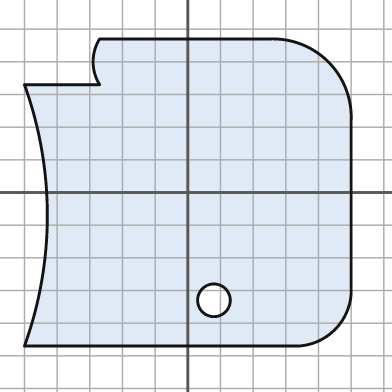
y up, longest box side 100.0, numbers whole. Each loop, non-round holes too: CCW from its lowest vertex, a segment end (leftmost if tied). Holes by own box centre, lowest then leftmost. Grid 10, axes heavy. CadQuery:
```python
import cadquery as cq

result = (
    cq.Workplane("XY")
    .moveTo(-50.0, -47.0)
    .lineTo(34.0, -47.0)
    .threePointArc((45.0, -42.0), (50.0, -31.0))
    .lineTo(50.0, 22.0)
    .threePointArc((43.0, 40.0), (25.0, 47.0))
    .lineTo(-27.0, 47.0)
    .threePointArc((-29.0, 40.0), (-27.0, 33.0))
    .lineTo(-50.0, 33.0)
    .threePointArc((-43.0, -7.0), (-50.0, -47.0))
    .close()
    .moveTo(8.0, -33.0)
    .circle(5.0)
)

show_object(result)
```